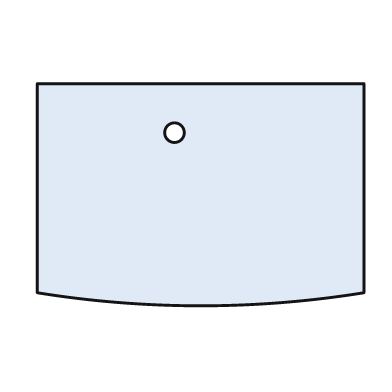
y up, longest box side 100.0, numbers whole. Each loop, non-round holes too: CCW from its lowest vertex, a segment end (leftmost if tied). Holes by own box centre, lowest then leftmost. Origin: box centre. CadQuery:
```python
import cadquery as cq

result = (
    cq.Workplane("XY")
    .moveTo(-50.0, -30.0)
    .threePointArc((0.0, -34.0), (50.0, -30.0))
    .lineTo(50.0, 34.0)
    .lineTo(-50.0, 34.0)
    .close()
    .moveTo(-8.0, 19.0)
    .circle(3.0)
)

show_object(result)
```